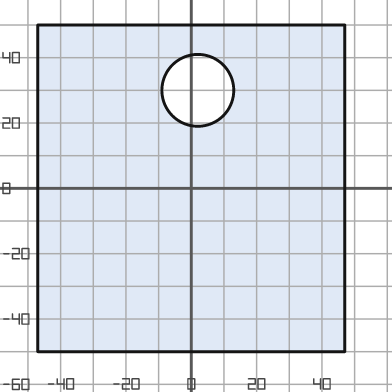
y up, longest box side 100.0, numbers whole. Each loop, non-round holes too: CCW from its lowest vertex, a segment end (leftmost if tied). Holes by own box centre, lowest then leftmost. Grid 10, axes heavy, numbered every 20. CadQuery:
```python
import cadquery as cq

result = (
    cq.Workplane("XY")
    .moveTo(-47.0, -50.0)
    .lineTo(47.0, -50.0)
    .lineTo(47.0, 50.0)
    .lineTo(-47.0, 50.0)
    .close()
    .moveTo(2.0, 30.0)
    .circle(11.0)
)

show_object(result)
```